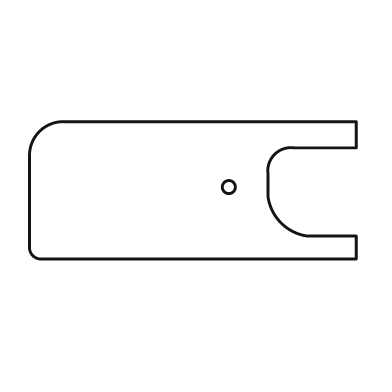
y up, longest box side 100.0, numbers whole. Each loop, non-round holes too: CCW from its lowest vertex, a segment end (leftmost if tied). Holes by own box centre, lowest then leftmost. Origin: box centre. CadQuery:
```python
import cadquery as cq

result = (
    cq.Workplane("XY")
    .moveTo(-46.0, -21.0)
    .lineTo(50.0, -21.0)
    .lineTo(50.0, -14.0)
    .lineTo(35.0, -14.0)
    .threePointArc((27.0, -10.0), (23.0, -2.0))
    .lineTo(23.0, 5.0)
    .threePointArc((25.0, 11.0), (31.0, 13.0))
    .lineTo(50.0, 13.0)
    .lineTo(50.0, 21.0)
    .lineTo(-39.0, 21.0)
    .threePointArc((-47.0, 18.0), (-50.0, 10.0))
    .lineTo(-50.0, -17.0)
    .threePointArc((-49.0, -20.0), (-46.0, -21.0))
    .close()
    .moveTo(11.0, 1.0)
    .circle(2.0)
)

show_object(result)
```